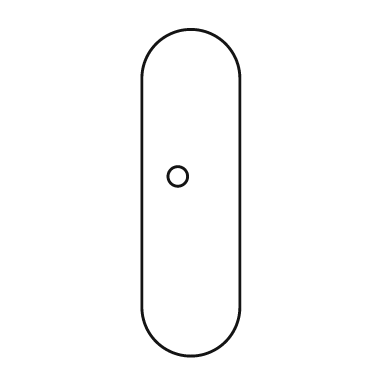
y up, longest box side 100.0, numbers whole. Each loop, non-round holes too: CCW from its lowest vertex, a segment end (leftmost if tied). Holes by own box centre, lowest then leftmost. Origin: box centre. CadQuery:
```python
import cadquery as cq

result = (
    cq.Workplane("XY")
    .moveTo(-15.0, -35.0)
    .threePointArc((0.0, -50.0), (15.0, -35.0))
    .lineTo(15.0, 35.0)
    .threePointArc((0.0, 50.0), (-15.0, 35.0))
    .close()
    .moveTo(-4.0, 5.0)
    .circle(3.0)
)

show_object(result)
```